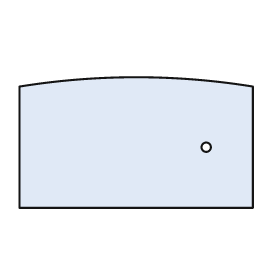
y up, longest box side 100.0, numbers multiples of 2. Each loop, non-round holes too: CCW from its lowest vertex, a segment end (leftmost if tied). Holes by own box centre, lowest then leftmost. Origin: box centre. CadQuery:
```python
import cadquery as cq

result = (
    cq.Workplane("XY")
    .moveTo(-50.0, -28.0)
    .lineTo(50.0, -28.0)
    .lineTo(50.0, 24.0)
    .threePointArc((0.0, 28.0), (-50.0, 24.0))
    .close()
    .moveTo(30.0, -2.0)
    .circle(2.0)
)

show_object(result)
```